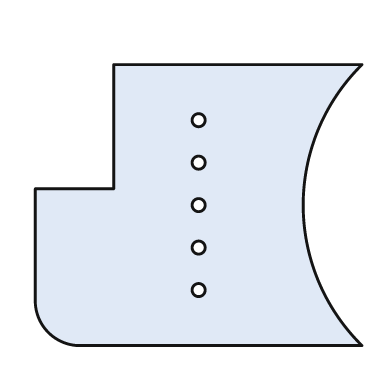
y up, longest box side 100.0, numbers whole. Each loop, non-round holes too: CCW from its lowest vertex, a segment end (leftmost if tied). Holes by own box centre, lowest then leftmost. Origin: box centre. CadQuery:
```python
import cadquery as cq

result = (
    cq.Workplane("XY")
    .moveTo(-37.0, -43.0)
    .lineTo(50.0, -43.0)
    .threePointArc((32.0, 0.0), (50.0, 43.0))
    .lineTo(-26.0, 43.0)
    .lineTo(-26.0, 5.0)
    .lineTo(-50.0, 5.0)
    .lineTo(-50.0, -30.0)
    .threePointArc((-46.0, -39.0), (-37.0, -43.0))
    .close()
    .moveTo(0.0, -26.0)
    .circle(2.0)
    .moveTo(0.0, -13.0)
    .circle(2.0)
    .moveTo(0.0, 0.0)
    .circle(2.0)
    .moveTo(0.0, 13.0)
    .circle(2.0)
    .moveTo(0.0, 26.0)
    .circle(2.0)
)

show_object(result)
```